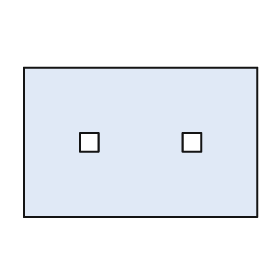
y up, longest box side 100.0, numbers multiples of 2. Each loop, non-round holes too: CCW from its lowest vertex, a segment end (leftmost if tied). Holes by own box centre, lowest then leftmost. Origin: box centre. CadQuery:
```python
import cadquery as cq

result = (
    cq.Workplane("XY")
    .moveTo(-50.0, -32.0)
    .lineTo(50.0, -32.0)
    .lineTo(50.0, 32.0)
    .lineTo(-50.0, 32.0)
    .close()
    .moveTo(-26.0, -4.0)
    .lineTo(-18.0, -4.0)
    .lineTo(-18.0, 4.0)
    .lineTo(-26.0, 4.0)
    .close()
    .moveTo(18.0, -4.0)
    .lineTo(26.0, -4.0)
    .lineTo(26.0, 4.0)
    .lineTo(18.0, 4.0)
    .close()
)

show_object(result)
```